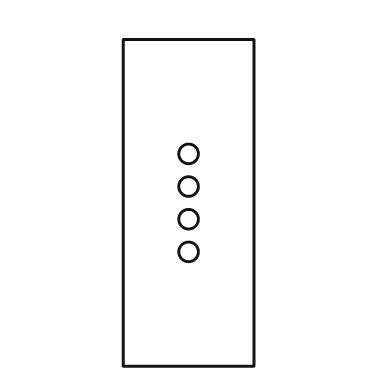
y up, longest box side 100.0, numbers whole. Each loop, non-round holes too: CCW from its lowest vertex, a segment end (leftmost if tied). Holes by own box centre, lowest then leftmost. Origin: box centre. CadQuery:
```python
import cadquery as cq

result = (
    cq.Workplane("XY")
    .moveTo(-20.0, -50.0)
    .lineTo(20.0, -50.0)
    .lineTo(20.0, 50.0)
    .lineTo(-20.0, 50.0)
    .close()
    .moveTo(0.0, -15.0)
    .circle(3.0)
    .moveTo(0.0, -5.0)
    .circle(3.0)
    .moveTo(0.0, 5.0)
    .circle(3.0)
    .moveTo(0.0, 15.0)
    .circle(3.0)
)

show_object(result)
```